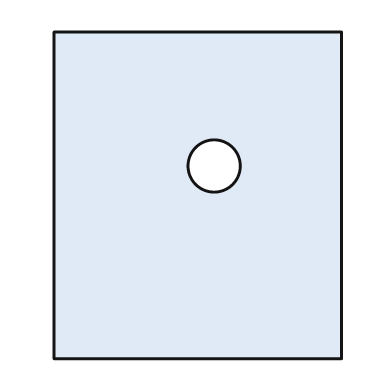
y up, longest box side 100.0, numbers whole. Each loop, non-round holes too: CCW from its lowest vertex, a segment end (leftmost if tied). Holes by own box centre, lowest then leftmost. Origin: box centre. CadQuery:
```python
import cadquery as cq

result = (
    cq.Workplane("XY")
    .moveTo(-44.0, -50.0)
    .lineTo(44.0, -50.0)
    .lineTo(44.0, 50.0)
    .lineTo(-44.0, 50.0)
    .close()
    .moveTo(5.0, 9.0)
    .circle(8.0)
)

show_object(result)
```